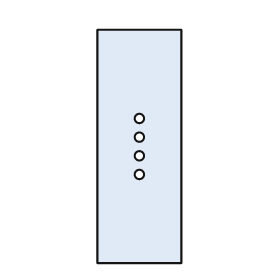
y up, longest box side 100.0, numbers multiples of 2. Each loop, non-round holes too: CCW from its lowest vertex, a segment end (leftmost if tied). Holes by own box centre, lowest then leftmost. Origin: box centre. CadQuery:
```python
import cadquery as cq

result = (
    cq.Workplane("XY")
    .moveTo(-18.0, -50.0)
    .lineTo(18.0, -50.0)
    .lineTo(18.0, 50.0)
    .lineTo(-18.0, 50.0)
    .close()
    .moveTo(0.0, -12.0)
    .circle(2.0)
    .moveTo(0.0, -4.0)
    .circle(2.0)
    .moveTo(0.0, 4.0)
    .circle(2.0)
    .moveTo(0.0, 12.0)
    .circle(2.0)
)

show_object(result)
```